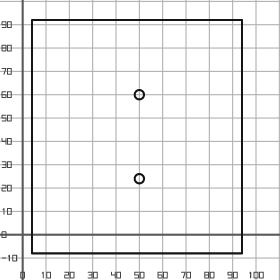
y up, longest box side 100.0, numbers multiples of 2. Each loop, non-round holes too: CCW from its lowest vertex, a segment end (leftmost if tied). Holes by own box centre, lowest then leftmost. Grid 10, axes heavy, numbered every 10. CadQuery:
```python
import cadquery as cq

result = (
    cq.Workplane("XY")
    .moveTo(4.0, -8.0)
    .lineTo(94.0, -8.0)
    .lineTo(94.0, 92.0)
    .lineTo(4.0, 92.0)
    .close()
    .moveTo(50.0, 24.0)
    .circle(2.0)
    .moveTo(50.0, 60.0)
    .circle(2.0)
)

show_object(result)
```